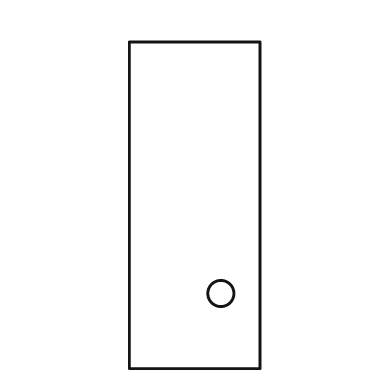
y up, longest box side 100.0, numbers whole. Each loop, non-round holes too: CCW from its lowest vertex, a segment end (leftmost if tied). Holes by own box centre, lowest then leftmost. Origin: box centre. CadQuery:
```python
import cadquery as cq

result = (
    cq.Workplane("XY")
    .moveTo(-20.0, -50.0)
    .lineTo(20.0, -50.0)
    .lineTo(20.0, 50.0)
    .lineTo(-20.0, 50.0)
    .close()
    .moveTo(8.0, -27.0)
    .circle(4.0)
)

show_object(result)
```